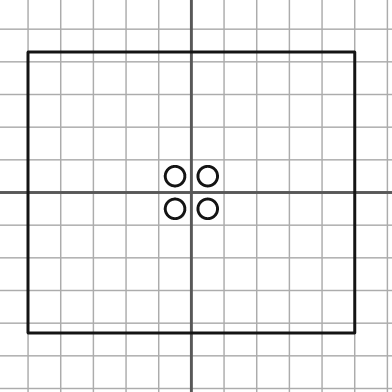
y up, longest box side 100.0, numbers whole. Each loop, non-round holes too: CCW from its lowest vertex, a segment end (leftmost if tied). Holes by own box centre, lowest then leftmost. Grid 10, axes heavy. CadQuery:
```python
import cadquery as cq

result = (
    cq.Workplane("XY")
    .moveTo(-50.0, -43.0)
    .lineTo(50.0, -43.0)
    .lineTo(50.0, 43.0)
    .lineTo(-50.0, 43.0)
    .close()
    .moveTo(-5.0, -5.0)
    .circle(3.0)
    .moveTo(5.0, -5.0)
    .circle(3.0)
    .moveTo(-5.0, 5.0)
    .circle(3.0)
    .moveTo(5.0, 5.0)
    .circle(3.0)
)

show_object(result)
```